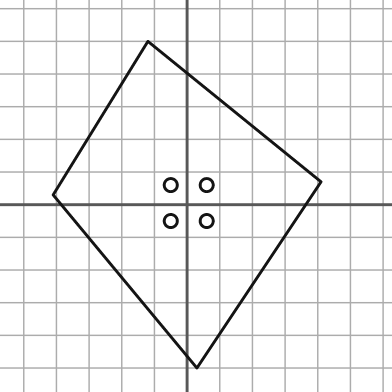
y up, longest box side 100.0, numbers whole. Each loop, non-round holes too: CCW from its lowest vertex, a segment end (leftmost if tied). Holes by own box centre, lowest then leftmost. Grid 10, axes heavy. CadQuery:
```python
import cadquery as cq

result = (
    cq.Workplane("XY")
    .moveTo(3.0, -50.0)
    .lineTo(41.0, 7.0)
    .lineTo(-12.0, 50.0)
    .lineTo(-41.0, 3.0)
    .close()
    .moveTo(-5.0, -5.0)
    .circle(2.0)
    .moveTo(6.0, -5.0)
    .circle(2.0)
    .moveTo(-5.0, 6.0)
    .circle(2.0)
    .moveTo(6.0, 6.0)
    .circle(2.0)
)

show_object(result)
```